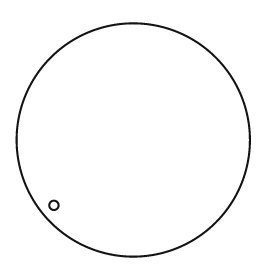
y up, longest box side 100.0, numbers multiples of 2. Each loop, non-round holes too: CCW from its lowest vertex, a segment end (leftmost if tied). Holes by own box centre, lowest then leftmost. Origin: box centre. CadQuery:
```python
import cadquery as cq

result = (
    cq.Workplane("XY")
    .moveTo(0.0, 0.0)
    .circle(50.0)
    .moveTo(-34.0, -28.0)
    .circle(2.0)
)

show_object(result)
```